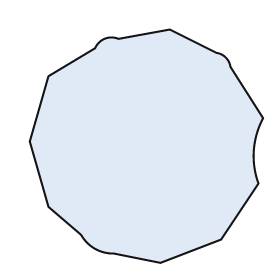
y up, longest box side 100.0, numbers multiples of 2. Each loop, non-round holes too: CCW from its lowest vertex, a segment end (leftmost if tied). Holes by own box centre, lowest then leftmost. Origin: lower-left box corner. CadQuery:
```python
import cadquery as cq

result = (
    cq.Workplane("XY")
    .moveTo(56.0, 0.0)
    .lineTo(82.0, 10.0)
    .lineTo(98.0, 34.0)
    .threePointArc((96.0, 48.0), (100.0, 62.0))
    .lineTo(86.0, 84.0)
    .threePointArc((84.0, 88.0), (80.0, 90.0))
    .lineTo(60.0, 100.0)
    .lineTo(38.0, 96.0)
    .threePointArc((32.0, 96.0), (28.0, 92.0))
    .lineTo(8.0, 80.0)
    .lineTo(0.0, 52.0)
    .lineTo(8.0, 24.0)
    .lineTo(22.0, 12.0)
    .threePointArc((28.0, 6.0), (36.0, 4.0))
    .close()
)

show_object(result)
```